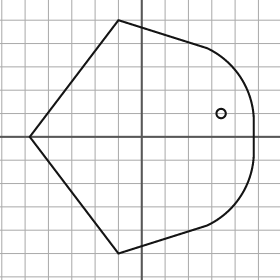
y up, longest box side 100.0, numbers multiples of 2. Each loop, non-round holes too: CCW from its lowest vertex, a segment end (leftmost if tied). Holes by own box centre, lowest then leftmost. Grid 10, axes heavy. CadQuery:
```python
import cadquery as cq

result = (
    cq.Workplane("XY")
    .moveTo(-10.0, -50.0)
    .lineTo(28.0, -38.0)
    .threePointArc((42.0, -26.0), (48.0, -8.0))
    .lineTo(48.0, 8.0)
    .threePointArc((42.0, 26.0), (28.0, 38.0))
    .lineTo(-10.0, 50.0)
    .lineTo(-48.0, 0.0)
    .close()
    .moveTo(34.0, 10.0)
    .circle(2.0)
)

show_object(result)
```